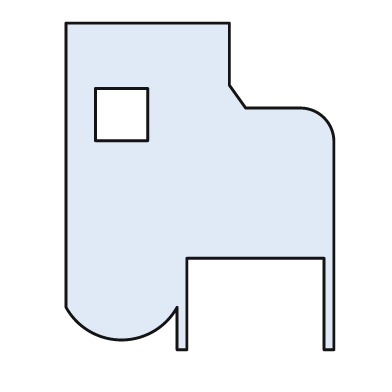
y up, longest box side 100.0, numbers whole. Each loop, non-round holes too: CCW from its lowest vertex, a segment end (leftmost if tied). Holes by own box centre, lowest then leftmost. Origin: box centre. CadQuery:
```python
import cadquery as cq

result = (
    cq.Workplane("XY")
    .moveTo(-7.0, -50.0)
    .lineTo(-4.0, -50.0)
    .lineTo(-4.0, -22.0)
    .lineTo(38.0, -22.0)
    .lineTo(38.0, -50.0)
    .lineTo(41.0, -50.0)
    .lineTo(41.0, 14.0)
    .threePointArc((38.0, 21.0), (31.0, 24.0))
    .lineTo(14.0, 24.0)
    .lineTo(9.0, 31.0)
    .lineTo(9.0, 50.0)
    .lineTo(-41.0, 50.0)
    .lineTo(-41.0, -37.0)
    .threePointArc((-24.0, -47.0), (-7.0, -37.0))
    .close()
    .moveTo(-32.0, 14.0)
    .lineTo(-16.0, 14.0)
    .lineTo(-16.0, 30.0)
    .lineTo(-32.0, 30.0)
    .close()
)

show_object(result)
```